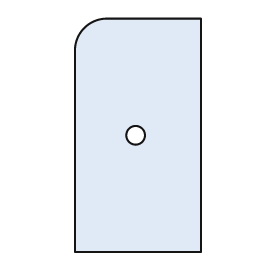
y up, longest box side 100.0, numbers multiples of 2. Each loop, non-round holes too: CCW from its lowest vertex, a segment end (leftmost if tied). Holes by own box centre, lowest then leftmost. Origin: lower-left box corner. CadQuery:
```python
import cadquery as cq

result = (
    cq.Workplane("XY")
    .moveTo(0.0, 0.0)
    .lineTo(54.0, 0.0)
    .lineTo(54.0, 100.0)
    .lineTo(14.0, 100.0)
    .threePointArc((4.0, 96.0), (0.0, 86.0))
    .close()
    .moveTo(26.0, 50.0)
    .circle(4.0)
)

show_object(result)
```